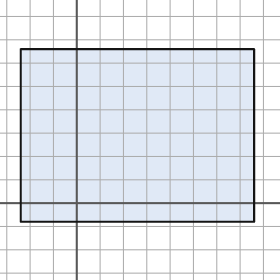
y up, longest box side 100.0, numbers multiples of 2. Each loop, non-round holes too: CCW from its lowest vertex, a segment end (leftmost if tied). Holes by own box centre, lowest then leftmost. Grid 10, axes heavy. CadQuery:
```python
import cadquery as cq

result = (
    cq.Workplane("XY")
    .moveTo(-24.0, -8.0)
    .lineTo(76.0, -8.0)
    .lineTo(76.0, 66.0)
    .lineTo(-24.0, 66.0)
    .close()
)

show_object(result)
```